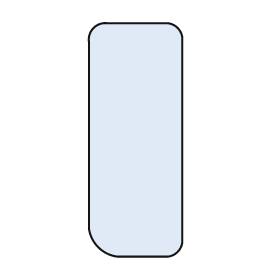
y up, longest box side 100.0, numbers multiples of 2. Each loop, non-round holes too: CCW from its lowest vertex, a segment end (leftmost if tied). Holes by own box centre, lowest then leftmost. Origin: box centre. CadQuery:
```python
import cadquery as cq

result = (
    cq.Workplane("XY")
    .moveTo(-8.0, -50.0)
    .lineTo(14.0, -50.0)
    .threePointArc((18.0, -48.0), (20.0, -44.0))
    .lineTo(20.0, 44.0)
    .threePointArc((18.0, 48.0), (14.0, 50.0))
    .lineTo(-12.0, 50.0)
    .threePointArc((-18.0, 48.0), (-20.0, 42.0))
    .lineTo(-20.0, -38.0)
    .threePointArc((-16.0, -46.0), (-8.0, -50.0))
    .close()
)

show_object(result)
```